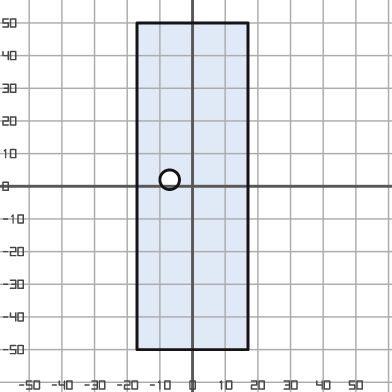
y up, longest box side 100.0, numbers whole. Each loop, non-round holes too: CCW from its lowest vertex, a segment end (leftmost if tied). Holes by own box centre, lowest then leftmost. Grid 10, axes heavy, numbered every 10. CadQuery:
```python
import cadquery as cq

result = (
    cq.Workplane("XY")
    .moveTo(-17.0, -50.0)
    .lineTo(17.0, -50.0)
    .lineTo(17.0, 50.0)
    .lineTo(-17.0, 50.0)
    .close()
    .moveTo(-7.0, 2.0)
    .circle(3.0)
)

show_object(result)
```